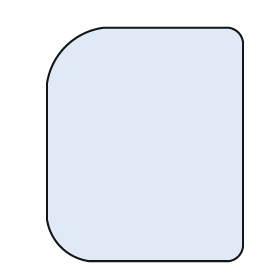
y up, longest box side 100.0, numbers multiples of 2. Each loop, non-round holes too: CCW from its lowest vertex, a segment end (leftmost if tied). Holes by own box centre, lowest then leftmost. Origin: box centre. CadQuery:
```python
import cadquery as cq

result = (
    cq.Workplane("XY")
    .moveTo(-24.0, -50.0)
    .lineTo(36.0, -50.0)
    .threePointArc((40.0, -48.0), (42.0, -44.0))
    .lineTo(42.0, 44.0)
    .threePointArc((40.0, 48.0), (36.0, 50.0))
    .lineTo(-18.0, 50.0)
    .threePointArc((-34.0, 42.0), (-42.0, 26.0))
    .lineTo(-42.0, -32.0)
    .threePointArc((-36.0, -44.0), (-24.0, -50.0))
    .close()
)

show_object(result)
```